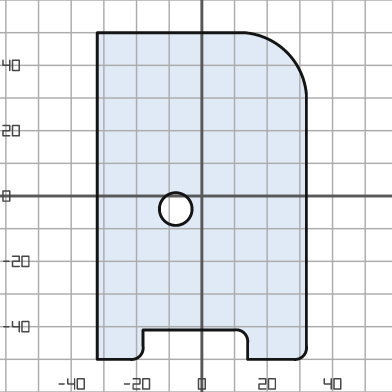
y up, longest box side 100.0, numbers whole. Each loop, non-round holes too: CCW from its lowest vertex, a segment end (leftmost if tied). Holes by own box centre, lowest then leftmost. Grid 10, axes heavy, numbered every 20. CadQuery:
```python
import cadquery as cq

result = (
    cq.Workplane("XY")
    .moveTo(-32.0, -50.0)
    .lineTo(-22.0, -50.0)
    .threePointArc((-19.0, -49.0), (-18.0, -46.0))
    .lineTo(-18.0, -41.0)
    .lineTo(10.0, -41.0)
    .threePointArc((13.0, -42.0), (14.0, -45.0))
    .lineTo(14.0, -50.0)
    .lineTo(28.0, -50.0)
    .threePointArc((31.0, -49.0), (32.0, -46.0))
    .lineTo(32.0, 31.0)
    .threePointArc((26.0, 44.0), (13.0, 50.0))
    .lineTo(-32.0, 50.0)
    .close()
    .moveTo(-8.0, -4.0)
    .circle(5.0)
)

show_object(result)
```